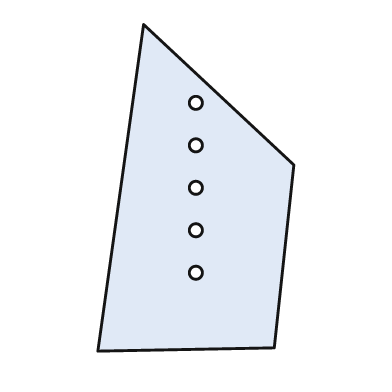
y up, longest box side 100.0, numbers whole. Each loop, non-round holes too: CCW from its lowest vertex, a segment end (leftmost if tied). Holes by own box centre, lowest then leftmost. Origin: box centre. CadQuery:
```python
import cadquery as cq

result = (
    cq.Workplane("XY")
    .moveTo(-30.0, -50.0)
    .lineTo(24.0, -49.0)
    .lineTo(30.0, 7.0)
    .lineTo(-16.0, 50.0)
    .close()
    .moveTo(0.0, -26.0)
    .circle(2.0)
    .moveTo(0.0, -13.0)
    .circle(2.0)
    .moveTo(0.0, 0.0)
    .circle(2.0)
    .moveTo(0.0, 13.0)
    .circle(2.0)
    .moveTo(0.0, 26.0)
    .circle(2.0)
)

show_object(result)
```